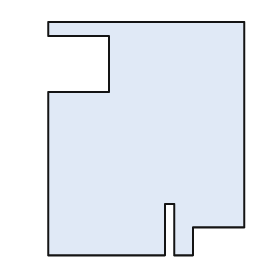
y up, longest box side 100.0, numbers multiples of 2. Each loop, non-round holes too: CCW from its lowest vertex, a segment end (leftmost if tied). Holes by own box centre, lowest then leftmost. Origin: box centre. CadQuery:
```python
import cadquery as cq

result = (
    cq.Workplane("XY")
    .moveTo(-42.0, -50.0)
    .lineTo(8.0, -50.0)
    .lineTo(8.0, -28.0)
    .lineTo(12.0, -28.0)
    .lineTo(12.0, -50.0)
    .lineTo(20.0, -50.0)
    .lineTo(20.0, -38.0)
    .lineTo(42.0, -38.0)
    .lineTo(42.0, 50.0)
    .lineTo(-42.0, 50.0)
    .lineTo(-42.0, 44.0)
    .lineTo(-16.0, 44.0)
    .lineTo(-16.0, 20.0)
    .lineTo(-42.0, 20.0)
    .close()
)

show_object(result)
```